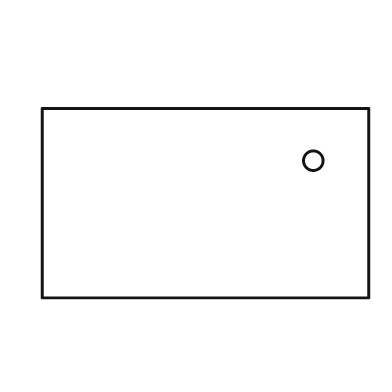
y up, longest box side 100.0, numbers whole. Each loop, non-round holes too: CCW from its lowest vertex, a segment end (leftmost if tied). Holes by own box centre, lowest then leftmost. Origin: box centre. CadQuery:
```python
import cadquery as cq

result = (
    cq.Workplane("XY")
    .moveTo(-50.0, -29.0)
    .lineTo(50.0, -29.0)
    .lineTo(50.0, 29.0)
    .lineTo(-50.0, 29.0)
    .close()
    .moveTo(33.0, 13.0)
    .circle(3.0)
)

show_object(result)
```